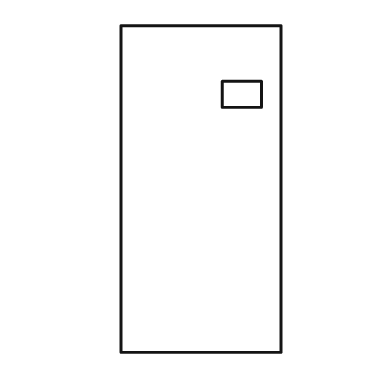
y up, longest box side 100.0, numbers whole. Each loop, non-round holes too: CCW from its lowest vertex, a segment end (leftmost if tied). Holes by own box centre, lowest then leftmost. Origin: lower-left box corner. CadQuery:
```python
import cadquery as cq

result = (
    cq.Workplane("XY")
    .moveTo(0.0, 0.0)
    .lineTo(49.0, 0.0)
    .lineTo(49.0, 100.0)
    .lineTo(0.0, 100.0)
    .close()
    .moveTo(31.0, 75.0)
    .lineTo(43.0, 75.0)
    .lineTo(43.0, 83.0)
    .lineTo(31.0, 83.0)
    .close()
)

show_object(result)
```